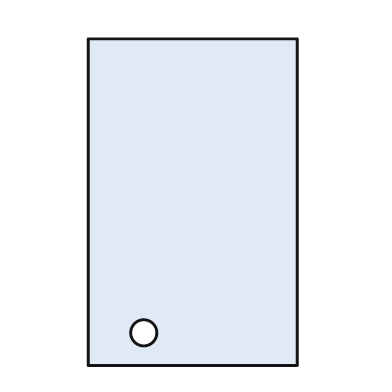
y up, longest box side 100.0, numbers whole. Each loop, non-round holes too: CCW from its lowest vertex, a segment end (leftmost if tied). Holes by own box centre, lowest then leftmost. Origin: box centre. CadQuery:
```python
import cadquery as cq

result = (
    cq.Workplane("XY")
    .moveTo(-32.0, -50.0)
    .lineTo(32.0, -50.0)
    .lineTo(32.0, 50.0)
    .lineTo(-32.0, 50.0)
    .close()
    .moveTo(-15.0, -40.0)
    .circle(4.0)
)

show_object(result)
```